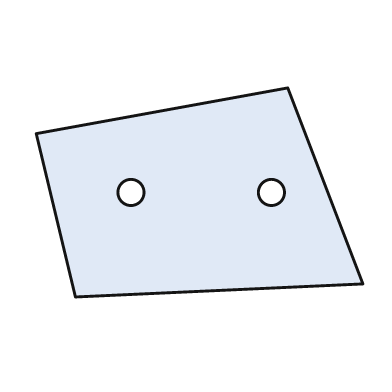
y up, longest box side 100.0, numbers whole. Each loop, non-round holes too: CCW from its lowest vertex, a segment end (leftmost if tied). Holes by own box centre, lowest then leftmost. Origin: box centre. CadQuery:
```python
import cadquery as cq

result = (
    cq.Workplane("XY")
    .moveTo(-38.0, -32.0)
    .lineTo(50.0, -28.0)
    .lineTo(27.0, 32.0)
    .lineTo(-50.0, 18.0)
    .close()
    .moveTo(-21.0, 0.0)
    .circle(4.0)
    .moveTo(22.0, 0.0)
    .circle(4.0)
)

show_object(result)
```